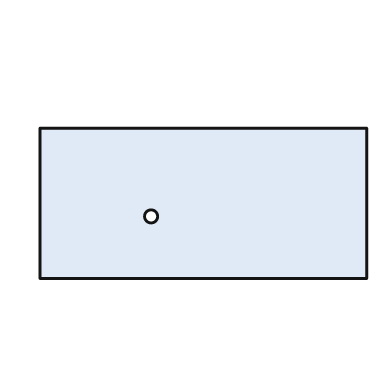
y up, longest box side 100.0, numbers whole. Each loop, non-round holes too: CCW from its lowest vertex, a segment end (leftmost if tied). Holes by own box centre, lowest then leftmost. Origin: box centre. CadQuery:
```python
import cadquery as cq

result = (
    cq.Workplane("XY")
    .moveTo(-50.0, -23.0)
    .lineTo(50.0, -23.0)
    .lineTo(50.0, 23.0)
    .lineTo(-50.0, 23.0)
    .close()
    .moveTo(-16.0, -4.0)
    .circle(2.0)
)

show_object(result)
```